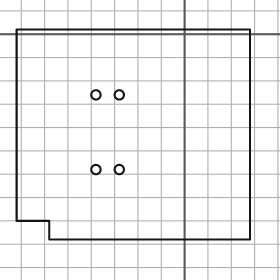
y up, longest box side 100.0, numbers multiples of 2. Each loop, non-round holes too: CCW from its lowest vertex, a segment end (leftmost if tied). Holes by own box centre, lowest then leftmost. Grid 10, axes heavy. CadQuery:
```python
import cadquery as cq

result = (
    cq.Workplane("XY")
    .moveTo(-58.0, -88.0)
    .lineTo(28.0, -88.0)
    .lineTo(28.0, 2.0)
    .lineTo(-72.0, 2.0)
    .lineTo(-72.0, -80.0)
    .lineTo(-58.0, -80.0)
    .close()
    .moveTo(-38.0, -58.0)
    .circle(2.0)
    .moveTo(-28.0, -58.0)
    .circle(2.0)
    .moveTo(-38.0, -26.0)
    .circle(2.0)
    .moveTo(-28.0, -26.0)
    .circle(2.0)
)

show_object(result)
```